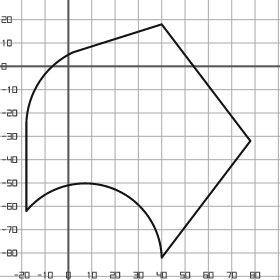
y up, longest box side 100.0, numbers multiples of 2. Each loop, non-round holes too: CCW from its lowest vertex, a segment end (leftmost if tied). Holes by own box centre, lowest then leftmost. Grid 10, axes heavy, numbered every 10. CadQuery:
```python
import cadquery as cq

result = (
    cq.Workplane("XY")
    .moveTo(40.0, -82.0)
    .lineTo(78.0, -32.0)
    .lineTo(40.0, 18.0)
    .lineTo(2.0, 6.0)
    .threePointArc((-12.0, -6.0), (-18.0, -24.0))
    .lineTo(-18.0, -62.0)
    .threePointArc((18.0, -52.0), (40.0, -82.0))
    .close()
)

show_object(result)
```